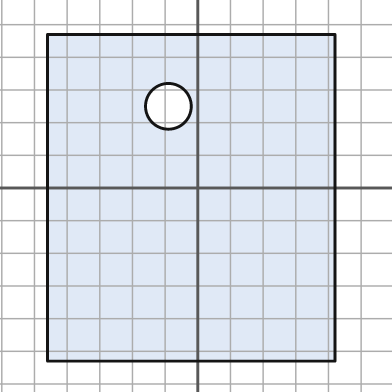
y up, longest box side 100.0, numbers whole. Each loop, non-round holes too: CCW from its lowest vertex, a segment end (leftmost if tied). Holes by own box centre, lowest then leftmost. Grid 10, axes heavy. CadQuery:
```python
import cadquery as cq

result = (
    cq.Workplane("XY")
    .moveTo(-46.0, -53.0)
    .lineTo(42.0, -53.0)
    .lineTo(42.0, 47.0)
    .lineTo(-46.0, 47.0)
    .close()
    .moveTo(-9.0, 25.0)
    .circle(7.0)
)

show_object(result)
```